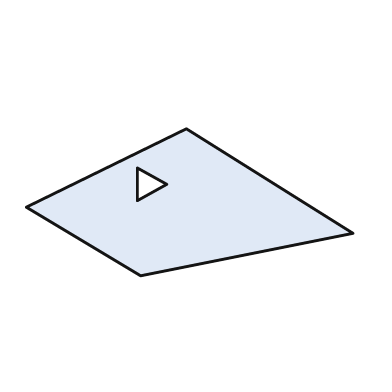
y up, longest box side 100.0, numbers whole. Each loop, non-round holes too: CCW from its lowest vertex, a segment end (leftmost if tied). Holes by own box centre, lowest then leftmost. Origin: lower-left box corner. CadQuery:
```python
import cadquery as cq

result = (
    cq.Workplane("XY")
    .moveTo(35.0, 0.0)
    .lineTo(100.0, 13.0)
    .lineTo(49.0, 45.0)
    .lineTo(0.0, 21.0)
    .close()
    .moveTo(34.0, 23.0)
    .lineTo(43.0, 28.0)
    .lineTo(34.0, 33.0)
    .close()
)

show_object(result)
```